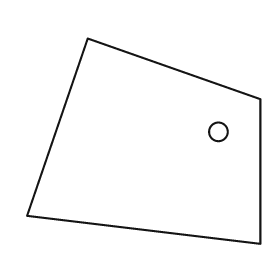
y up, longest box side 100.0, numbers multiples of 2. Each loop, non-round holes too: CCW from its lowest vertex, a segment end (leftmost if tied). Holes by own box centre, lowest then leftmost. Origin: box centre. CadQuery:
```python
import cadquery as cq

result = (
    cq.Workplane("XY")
    .moveTo(50.0, -44.0)
    .lineTo(50.0, 18.0)
    .lineTo(-24.0, 44.0)
    .lineTo(-50.0, -32.0)
    .close()
    .moveTo(32.0, 4.0)
    .circle(4.0)
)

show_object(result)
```